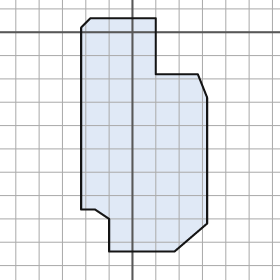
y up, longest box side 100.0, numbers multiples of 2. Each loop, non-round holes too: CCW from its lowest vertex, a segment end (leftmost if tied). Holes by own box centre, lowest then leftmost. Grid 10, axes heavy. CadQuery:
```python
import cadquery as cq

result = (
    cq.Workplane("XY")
    .moveTo(-10.0, -94.0)
    .lineTo(18.0, -94.0)
    .lineTo(32.0, -82.0)
    .lineTo(32.0, -28.0)
    .lineTo(28.0, -18.0)
    .lineTo(10.0, -18.0)
    .lineTo(10.0, 6.0)
    .lineTo(-18.0, 6.0)
    .lineTo(-22.0, 2.0)
    .lineTo(-22.0, -76.0)
    .lineTo(-16.0, -76.0)
    .lineTo(-10.0, -80.0)
    .close()
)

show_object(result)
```